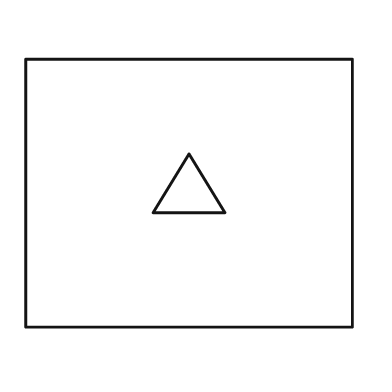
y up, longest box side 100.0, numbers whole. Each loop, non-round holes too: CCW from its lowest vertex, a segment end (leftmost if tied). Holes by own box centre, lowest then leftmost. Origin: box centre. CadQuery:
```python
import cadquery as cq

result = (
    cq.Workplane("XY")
    .moveTo(-50.0, -41.0)
    .lineTo(50.0, -41.0)
    .lineTo(50.0, 41.0)
    .lineTo(-50.0, 41.0)
    .close()
    .moveTo(-11.0, -6.0)
    .lineTo(11.0, -6.0)
    .lineTo(0.0, 12.0)
    .close()
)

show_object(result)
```